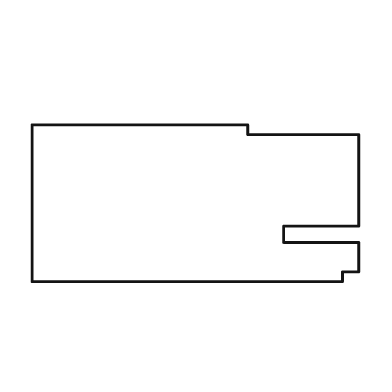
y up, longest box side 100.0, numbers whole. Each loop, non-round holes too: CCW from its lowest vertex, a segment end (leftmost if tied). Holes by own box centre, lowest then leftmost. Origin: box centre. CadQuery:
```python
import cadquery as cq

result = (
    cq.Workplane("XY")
    .moveTo(-50.0, -24.0)
    .lineTo(45.0, -24.0)
    .lineTo(45.0, -21.0)
    .lineTo(50.0, -21.0)
    .lineTo(50.0, -12.0)
    .lineTo(27.0, -12.0)
    .lineTo(27.0, -7.0)
    .lineTo(50.0, -7.0)
    .lineTo(50.0, 21.0)
    .lineTo(16.0, 21.0)
    .lineTo(16.0, 24.0)
    .lineTo(-50.0, 24.0)
    .close()
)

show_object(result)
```